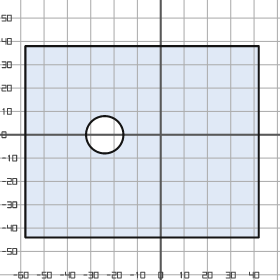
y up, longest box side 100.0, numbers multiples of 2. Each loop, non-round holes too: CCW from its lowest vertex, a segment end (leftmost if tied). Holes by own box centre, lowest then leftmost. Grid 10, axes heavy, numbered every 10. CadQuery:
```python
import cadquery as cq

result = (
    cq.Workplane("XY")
    .moveTo(-58.0, -44.0)
    .lineTo(42.0, -44.0)
    .lineTo(42.0, 38.0)
    .lineTo(-58.0, 38.0)
    .close()
    .moveTo(-24.0, 0.0)
    .circle(8.0)
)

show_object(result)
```